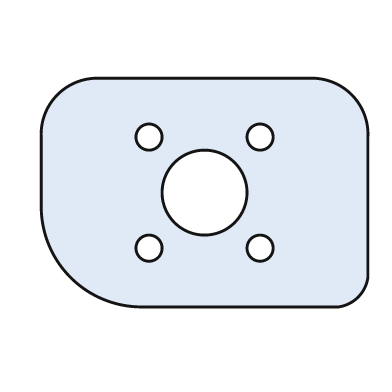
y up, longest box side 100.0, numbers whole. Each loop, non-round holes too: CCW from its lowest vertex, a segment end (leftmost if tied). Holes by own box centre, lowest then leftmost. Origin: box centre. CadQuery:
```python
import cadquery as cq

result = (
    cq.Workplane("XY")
    .moveTo(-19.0, -35.0)
    .lineTo(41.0, -35.0)
    .threePointArc((47.0, -32.0), (50.0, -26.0))
    .lineTo(50.0, 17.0)
    .threePointArc((45.0, 30.0), (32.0, 35.0))
    .lineTo(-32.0, 35.0)
    .threePointArc((-45.0, 30.0), (-50.0, 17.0))
    .lineTo(-50.0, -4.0)
    .threePointArc((-41.0, -26.0), (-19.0, -35.0))
    .close()
    .moveTo(-17.0, -17.0)
    .circle(4.0)
    .moveTo(17.0, -17.0)
    .circle(4.0)
    .moveTo(0.0, 0.0)
    .circle(13.0)
    .moveTo(-17.0, 17.0)
    .circle(4.0)
    .moveTo(17.0, 17.0)
    .circle(4.0)
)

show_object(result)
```